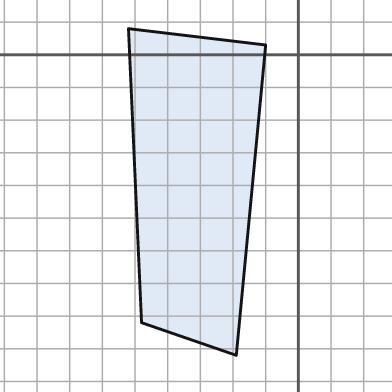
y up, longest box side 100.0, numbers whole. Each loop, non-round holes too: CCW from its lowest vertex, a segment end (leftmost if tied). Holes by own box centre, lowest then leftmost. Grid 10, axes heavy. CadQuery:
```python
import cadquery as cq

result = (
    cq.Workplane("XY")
    .moveTo(-19.0, -92.0)
    .lineTo(-10.0, 3.0)
    .lineTo(-52.0, 8.0)
    .lineTo(-48.0, -82.0)
    .close()
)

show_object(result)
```